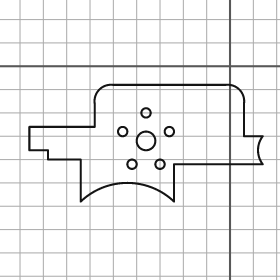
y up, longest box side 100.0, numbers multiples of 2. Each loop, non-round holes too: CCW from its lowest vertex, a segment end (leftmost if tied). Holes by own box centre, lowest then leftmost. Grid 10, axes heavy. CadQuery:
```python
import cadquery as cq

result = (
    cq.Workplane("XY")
    .moveTo(-64.0, -58.0)
    .threePointArc((-44.0, -50.0), (-24.0, -58.0))
    .lineTo(-24.0, -42.0)
    .lineTo(14.0, -42.0)
    .threePointArc((12.0, -36.0), (14.0, -30.0))
    .lineTo(6.0, -30.0)
    .lineTo(6.0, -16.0)
    .threePointArc((4.0, -10.0), (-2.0, -8.0))
    .lineTo(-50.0, -8.0)
    .threePointArc((-56.0, -10.0), (-58.0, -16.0))
    .lineTo(-58.0, -26.0)
    .lineTo(-86.0, -26.0)
    .lineTo(-86.0, -36.0)
    .lineTo(-78.0, -36.0)
    .lineTo(-78.0, -40.0)
    .lineTo(-64.0, -40.0)
    .close()
    .moveTo(-42.0, -42.0)
    .circle(2.0)
    .moveTo(-30.0, -42.0)
    .circle(2.0)
    .moveTo(-36.0, -32.0)
    .circle(4.0)
    .moveTo(-46.0, -28.0)
    .circle(2.0)
    .moveTo(-26.0, -28.0)
    .circle(2.0)
    .moveTo(-36.0, -20.0)
    .circle(2.0)
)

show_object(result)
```